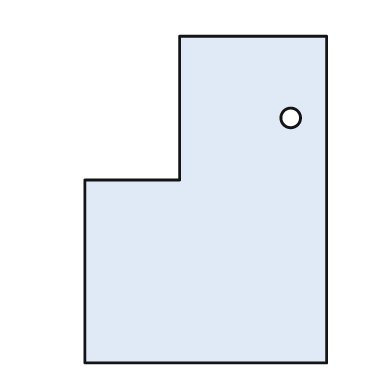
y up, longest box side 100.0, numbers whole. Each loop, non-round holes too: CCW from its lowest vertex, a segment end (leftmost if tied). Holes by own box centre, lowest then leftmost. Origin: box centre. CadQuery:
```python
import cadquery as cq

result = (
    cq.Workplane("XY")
    .moveTo(-37.0, -50.0)
    .lineTo(37.0, -50.0)
    .lineTo(37.0, 50.0)
    .lineTo(-8.0, 50.0)
    .lineTo(-8.0, 6.0)
    .lineTo(-37.0, 6.0)
    .close()
    .moveTo(26.0, 25.0)
    .circle(3.0)
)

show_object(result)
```